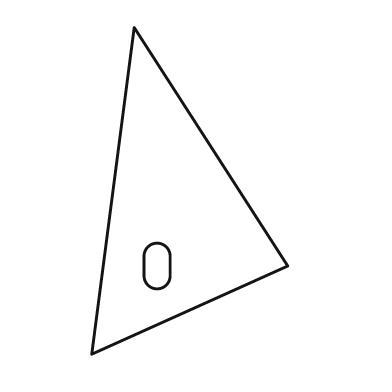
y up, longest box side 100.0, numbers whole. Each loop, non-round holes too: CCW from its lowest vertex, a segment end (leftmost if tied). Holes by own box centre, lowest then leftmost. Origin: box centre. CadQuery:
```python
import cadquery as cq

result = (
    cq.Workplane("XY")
    .moveTo(-30.0, -50.0)
    .lineTo(30.0, -23.0)
    .lineTo(-17.0, 50.0)
    .close()
    .moveTo(-14.0, -26.0)
    .threePointArc((-10.0, -30.0), (-6.0, -26.0))
    .lineTo(-6.0, -20.0)
    .threePointArc((-10.0, -16.0), (-14.0, -20.0))
    .close()
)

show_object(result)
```